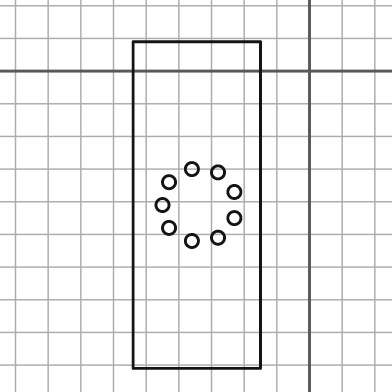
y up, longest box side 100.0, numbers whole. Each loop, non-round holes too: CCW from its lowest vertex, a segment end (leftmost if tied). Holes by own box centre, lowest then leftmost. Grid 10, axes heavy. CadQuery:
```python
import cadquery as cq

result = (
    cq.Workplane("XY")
    .moveTo(-54.0, -91.0)
    .lineTo(-15.0, -91.0)
    .lineTo(-15.0, 9.0)
    .lineTo(-54.0, 9.0)
    .close()
    .moveTo(-36.0, -52.0)
    .circle(2.0)
    .moveTo(-28.0, -51.0)
    .circle(2.0)
    .moveTo(-43.0, -48.0)
    .circle(2.0)
    .moveTo(-23.0, -45.0)
    .circle(2.0)
    .moveTo(-45.0, -41.0)
    .circle(2.0)
    .moveTo(-23.0, -37.0)
    .circle(2.0)
    .moveTo(-43.0, -34.0)
    .circle(2.0)
    .moveTo(-28.0, -31.0)
    .circle(2.0)
    .moveTo(-36.0, -30.0)
    .circle(2.0)
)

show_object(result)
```